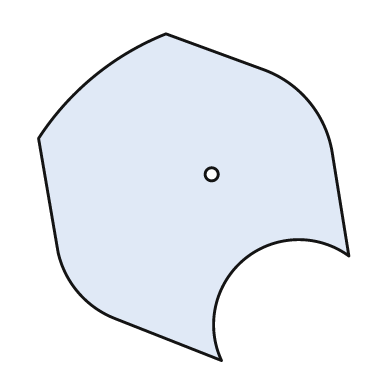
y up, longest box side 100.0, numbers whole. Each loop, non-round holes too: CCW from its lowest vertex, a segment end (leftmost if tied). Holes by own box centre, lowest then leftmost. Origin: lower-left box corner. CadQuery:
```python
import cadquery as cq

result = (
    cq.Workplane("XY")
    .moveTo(56.0, 0.0)
    .threePointArc((63.0, 31.0), (95.0, 32.0))
    .lineTo(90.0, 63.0)
    .threePointArc((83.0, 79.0), (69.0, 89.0))
    .lineTo(39.0, 100.0)
    .threePointArc((17.0, 87.0), (0.0, 68.0))
    .lineTo(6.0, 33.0)
    .threePointArc((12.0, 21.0), (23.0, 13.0))
    .close()
    .moveTo(53.0, 57.0)
    .circle(2.0)
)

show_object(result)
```